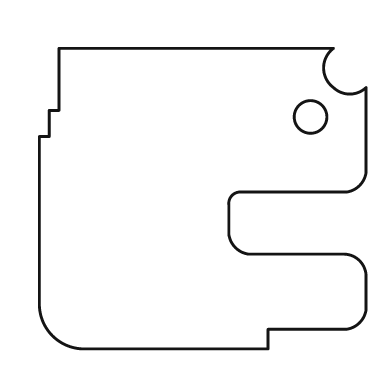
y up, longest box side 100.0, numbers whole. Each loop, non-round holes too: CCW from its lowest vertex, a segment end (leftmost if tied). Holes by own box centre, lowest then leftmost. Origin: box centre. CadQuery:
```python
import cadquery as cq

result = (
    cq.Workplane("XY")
    .moveTo(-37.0, -46.0)
    .lineTo(20.0, -46.0)
    .lineTo(20.0, -40.0)
    .lineTo(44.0, -40.0)
    .threePointArc((48.0, -38.0), (50.0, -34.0))
    .lineTo(50.0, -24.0)
    .threePointArc((48.0, -19.0), (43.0, -17.0))
    .lineTo(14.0, -17.0)
    .threePointArc((10.0, -15.0), (8.0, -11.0))
    .lineTo(8.0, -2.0)
    .threePointArc((9.0, 1.0), (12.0, 2.0))
    .lineTo(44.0, 2.0)
    .threePointArc((48.0, 4.0), (50.0, 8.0))
    .lineTo(50.0, 34.0)
    .threePointArc((45.0, 32.0), (40.0, 34.0))
    .threePointArc((37.0, 40.0), (40.0, 46.0))
    .lineTo(-44.0, 46.0)
    .lineTo(-44.0, 27.0)
    .lineTo(-47.0, 27.0)
    .lineTo(-47.0, 19.0)
    .lineTo(-50.0, 19.0)
    .lineTo(-50.0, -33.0)
    .threePointArc((-46.0, -42.0), (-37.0, -46.0))
    .close()
    .moveTo(33.0, 25.0)
    .circle(5.0)
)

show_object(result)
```